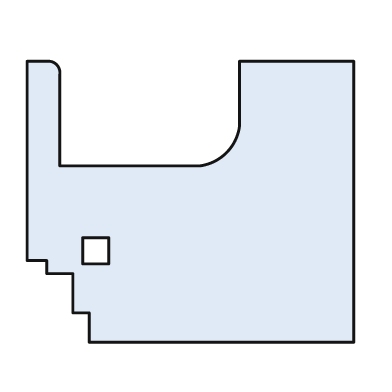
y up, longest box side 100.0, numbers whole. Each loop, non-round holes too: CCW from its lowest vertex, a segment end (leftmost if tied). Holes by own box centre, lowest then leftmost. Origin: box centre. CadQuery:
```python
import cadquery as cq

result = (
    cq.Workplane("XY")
    .moveTo(-31.0, -43.0)
    .lineTo(50.0, -43.0)
    .lineTo(50.0, 43.0)
    .lineTo(15.0, 43.0)
    .lineTo(15.0, 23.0)
    .threePointArc((11.0, 15.0), (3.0, 11.0))
    .lineTo(-40.0, 11.0)
    .lineTo(-40.0, 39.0)
    .threePointArc((-41.0, 42.0), (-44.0, 43.0))
    .lineTo(-50.0, 43.0)
    .lineTo(-50.0, -18.0)
    .lineTo(-44.0, -18.0)
    .lineTo(-44.0, -22.0)
    .lineTo(-36.0, -22.0)
    .lineTo(-36.0, -34.0)
    .lineTo(-31.0, -34.0)
    .close()
    .moveTo(-33.0, -19.0)
    .lineTo(-25.0, -19.0)
    .lineTo(-25.0, -11.0)
    .lineTo(-33.0, -11.0)
    .close()
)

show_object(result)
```